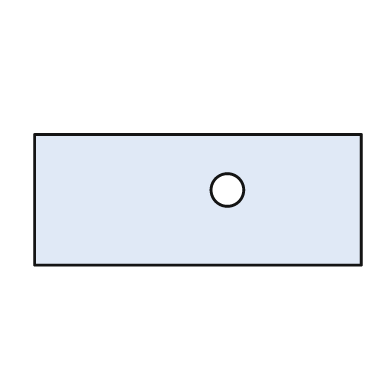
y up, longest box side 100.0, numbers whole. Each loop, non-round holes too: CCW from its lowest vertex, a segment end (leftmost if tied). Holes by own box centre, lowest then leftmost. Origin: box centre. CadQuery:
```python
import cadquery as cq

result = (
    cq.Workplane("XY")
    .moveTo(-50.0, -20.0)
    .lineTo(50.0, -20.0)
    .lineTo(50.0, 20.0)
    .lineTo(-50.0, 20.0)
    .close()
    .moveTo(9.0, 3.0)
    .circle(5.0)
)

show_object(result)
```